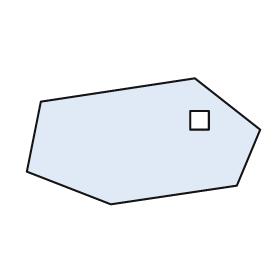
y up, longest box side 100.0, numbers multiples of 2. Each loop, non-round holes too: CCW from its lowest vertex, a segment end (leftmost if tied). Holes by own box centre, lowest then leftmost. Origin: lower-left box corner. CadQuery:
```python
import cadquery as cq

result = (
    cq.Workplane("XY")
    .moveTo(36.0, 0.0)
    .lineTo(90.0, 8.0)
    .lineTo(100.0, 32.0)
    .lineTo(72.0, 54.0)
    .lineTo(6.0, 44.0)
    .lineTo(0.0, 14.0)
    .close()
    .moveTo(70.0, 32.0)
    .lineTo(78.0, 32.0)
    .lineTo(78.0, 40.0)
    .lineTo(70.0, 40.0)
    .close()
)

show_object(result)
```